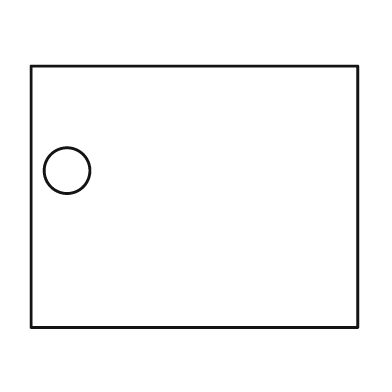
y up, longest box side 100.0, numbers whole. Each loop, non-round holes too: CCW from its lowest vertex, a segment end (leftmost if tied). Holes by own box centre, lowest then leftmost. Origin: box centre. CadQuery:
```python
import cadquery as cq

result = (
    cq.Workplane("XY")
    .moveTo(-50.0, -40.0)
    .lineTo(50.0, -40.0)
    .lineTo(50.0, 40.0)
    .lineTo(-50.0, 40.0)
    .close()
    .moveTo(-39.0, 8.0)
    .circle(7.0)
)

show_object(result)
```